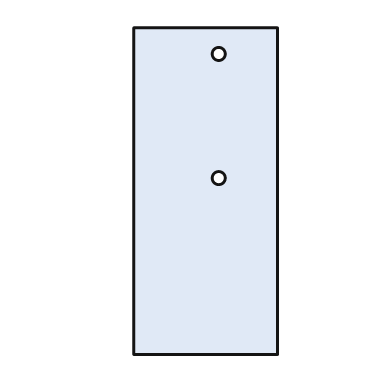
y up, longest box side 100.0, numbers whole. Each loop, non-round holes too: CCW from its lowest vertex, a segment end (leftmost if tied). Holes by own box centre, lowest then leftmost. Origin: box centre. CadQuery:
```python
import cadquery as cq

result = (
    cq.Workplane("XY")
    .moveTo(-22.0, -50.0)
    .lineTo(22.0, -50.0)
    .lineTo(22.0, 50.0)
    .lineTo(-22.0, 50.0)
    .close()
    .moveTo(4.0, 4.0)
    .circle(2.0)
    .moveTo(4.0, 42.0)
    .circle(2.0)
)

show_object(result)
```